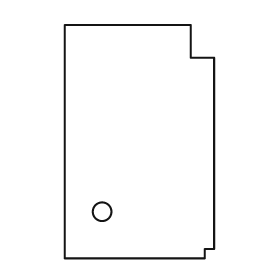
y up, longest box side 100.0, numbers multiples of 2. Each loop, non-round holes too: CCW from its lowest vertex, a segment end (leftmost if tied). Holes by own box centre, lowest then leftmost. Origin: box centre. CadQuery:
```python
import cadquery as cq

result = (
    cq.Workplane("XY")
    .moveTo(-32.0, -50.0)
    .lineTo(28.0, -50.0)
    .lineTo(28.0, -46.0)
    .lineTo(32.0, -46.0)
    .lineTo(32.0, 36.0)
    .lineTo(22.0, 36.0)
    .lineTo(22.0, 50.0)
    .lineTo(-32.0, 50.0)
    .close()
    .moveTo(-16.0, -30.0)
    .circle(4.0)
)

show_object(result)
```